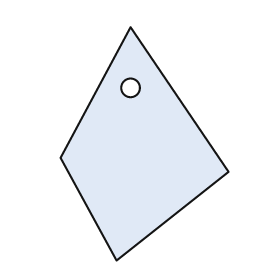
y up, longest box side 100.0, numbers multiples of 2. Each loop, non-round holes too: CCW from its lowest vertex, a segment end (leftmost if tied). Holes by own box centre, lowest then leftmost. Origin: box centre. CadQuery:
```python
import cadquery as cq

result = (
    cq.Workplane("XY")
    .moveTo(-12.0, -50.0)
    .lineTo(36.0, -12.0)
    .lineTo(-6.0, 50.0)
    .lineTo(-36.0, -6.0)
    .close()
    .moveTo(-6.0, 24.0)
    .circle(4.0)
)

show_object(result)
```